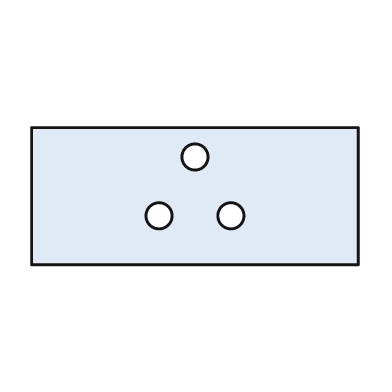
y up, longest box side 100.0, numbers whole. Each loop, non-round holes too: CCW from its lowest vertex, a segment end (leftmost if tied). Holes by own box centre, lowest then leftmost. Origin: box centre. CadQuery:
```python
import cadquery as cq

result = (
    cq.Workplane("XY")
    .moveTo(-50.0, -21.0)
    .lineTo(50.0, -21.0)
    .lineTo(50.0, 21.0)
    .lineTo(-50.0, 21.0)
    .close()
    .moveTo(-11.0, -6.0)
    .circle(4.0)
    .moveTo(11.0, -6.0)
    .circle(4.0)
    .moveTo(0.0, 12.0)
    .circle(4.0)
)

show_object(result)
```